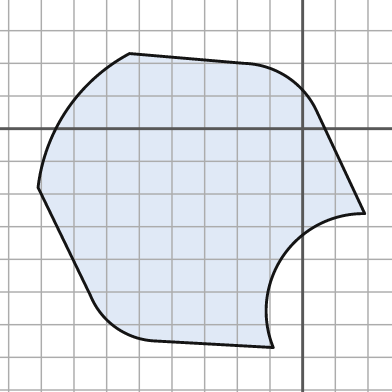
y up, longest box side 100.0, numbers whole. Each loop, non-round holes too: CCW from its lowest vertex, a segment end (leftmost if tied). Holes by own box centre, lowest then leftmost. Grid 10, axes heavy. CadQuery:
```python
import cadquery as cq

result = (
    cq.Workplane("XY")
    .moveTo(-9.0, -67.0)
    .threePointArc((-6.0, -39.0), (19.0, -26.0))
    .lineTo(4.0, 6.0)
    .threePointArc((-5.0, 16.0), (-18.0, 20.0))
    .lineTo(-53.0, 23.0)
    .threePointArc((-72.0, 6.0), (-81.0, -18.0))
    .lineTo(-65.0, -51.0)
    .threePointArc((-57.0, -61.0), (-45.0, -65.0))
    .close()
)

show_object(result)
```